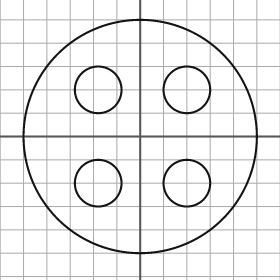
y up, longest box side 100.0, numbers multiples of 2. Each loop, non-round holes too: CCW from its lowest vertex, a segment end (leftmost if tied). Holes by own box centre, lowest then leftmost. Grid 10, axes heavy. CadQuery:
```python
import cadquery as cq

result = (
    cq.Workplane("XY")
    .moveTo(0.0, 0.0)
    .circle(50.0)
    .moveTo(-18.0, -20.0)
    .circle(10.0)
    .moveTo(20.0, -20.0)
    .circle(10.0)
    .moveTo(-18.0, 20.0)
    .circle(10.0)
    .moveTo(20.0, 20.0)
    .circle(10.0)
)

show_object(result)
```